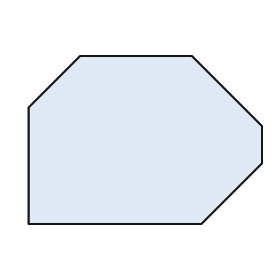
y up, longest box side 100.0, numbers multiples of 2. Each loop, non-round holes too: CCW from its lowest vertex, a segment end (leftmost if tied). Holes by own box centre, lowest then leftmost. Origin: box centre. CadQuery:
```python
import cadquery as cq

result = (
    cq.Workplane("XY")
    .moveTo(-50.0, -36.0)
    .lineTo(24.0, -36.0)
    .lineTo(50.0, -10.0)
    .lineTo(50.0, 6.0)
    .lineTo(20.0, 36.0)
    .lineTo(-28.0, 36.0)
    .lineTo(-50.0, 14.0)
    .close()
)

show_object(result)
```